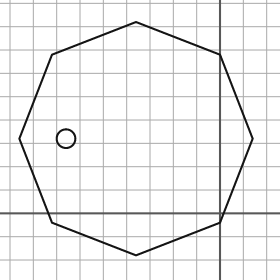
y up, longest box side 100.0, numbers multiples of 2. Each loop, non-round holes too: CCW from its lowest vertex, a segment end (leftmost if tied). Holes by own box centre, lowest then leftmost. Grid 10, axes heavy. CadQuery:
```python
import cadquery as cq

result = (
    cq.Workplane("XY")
    .moveTo(-36.0, -18.0)
    .lineTo(0.0, -4.0)
    .lineTo(14.0, 32.0)
    .lineTo(0.0, 68.0)
    .lineTo(-36.0, 82.0)
    .lineTo(-72.0, 68.0)
    .lineTo(-86.0, 32.0)
    .lineTo(-72.0, -4.0)
    .close()
    .moveTo(-66.0, 32.0)
    .circle(4.0)
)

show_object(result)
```